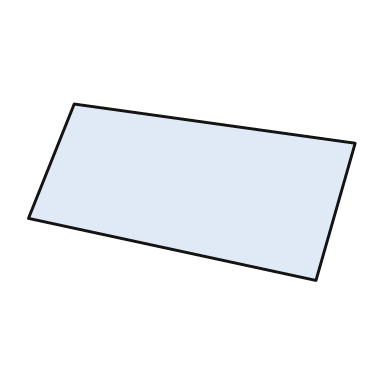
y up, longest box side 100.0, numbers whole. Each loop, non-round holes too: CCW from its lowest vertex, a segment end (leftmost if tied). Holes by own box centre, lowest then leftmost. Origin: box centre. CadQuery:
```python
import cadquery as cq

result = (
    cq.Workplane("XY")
    .moveTo(38.0, -27.0)
    .lineTo(50.0, 15.0)
    .lineTo(-36.0, 27.0)
    .lineTo(-50.0, -8.0)
    .close()
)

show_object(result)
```